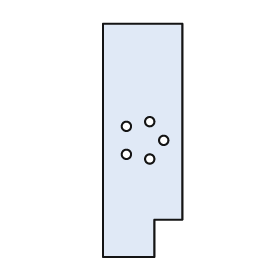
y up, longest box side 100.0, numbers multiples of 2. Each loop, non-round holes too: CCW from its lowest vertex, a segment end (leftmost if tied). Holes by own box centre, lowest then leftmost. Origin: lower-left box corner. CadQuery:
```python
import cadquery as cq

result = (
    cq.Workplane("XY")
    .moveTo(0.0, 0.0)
    .lineTo(22.0, 0.0)
    .lineTo(22.0, 16.0)
    .lineTo(34.0, 16.0)
    .lineTo(34.0, 100.0)
    .lineTo(0.0, 100.0)
    .close()
    .moveTo(20.0, 42.0)
    .circle(2.0)
    .moveTo(10.0, 44.0)
    .circle(2.0)
    .moveTo(26.0, 50.0)
    .circle(2.0)
    .moveTo(10.0, 56.0)
    .circle(2.0)
    .moveTo(20.0, 58.0)
    .circle(2.0)
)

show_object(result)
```